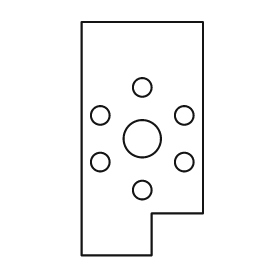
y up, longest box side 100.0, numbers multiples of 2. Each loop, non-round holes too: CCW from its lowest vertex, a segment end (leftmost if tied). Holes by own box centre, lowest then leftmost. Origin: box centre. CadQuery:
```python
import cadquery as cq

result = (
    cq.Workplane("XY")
    .moveTo(-26.0, -50.0)
    .lineTo(4.0, -50.0)
    .lineTo(4.0, -32.0)
    .lineTo(26.0, -32.0)
    .lineTo(26.0, 50.0)
    .lineTo(-26.0, 50.0)
    .close()
    .moveTo(0.0, -22.0)
    .circle(4.0)
    .moveTo(-18.0, -10.0)
    .circle(4.0)
    .moveTo(18.0, -10.0)
    .circle(4.0)
    .moveTo(0.0, 0.0)
    .circle(8.0)
    .moveTo(-18.0, 10.0)
    .circle(4.0)
    .moveTo(18.0, 10.0)
    .circle(4.0)
    .moveTo(0.0, 22.0)
    .circle(4.0)
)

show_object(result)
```